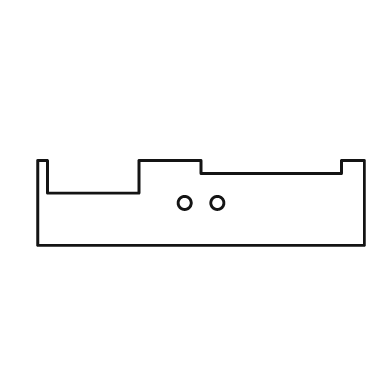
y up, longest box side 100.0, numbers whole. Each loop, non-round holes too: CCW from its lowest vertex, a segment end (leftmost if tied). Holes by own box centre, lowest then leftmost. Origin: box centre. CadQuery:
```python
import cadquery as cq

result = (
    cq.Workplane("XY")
    .moveTo(-50.0, -13.0)
    .lineTo(50.0, -13.0)
    .lineTo(50.0, 13.0)
    .lineTo(43.0, 13.0)
    .lineTo(43.0, 9.0)
    .lineTo(0.0, 9.0)
    .lineTo(0.0, 13.0)
    .lineTo(-19.0, 13.0)
    .lineTo(-19.0, 3.0)
    .lineTo(-47.0, 3.0)
    .lineTo(-47.0, 13.0)
    .lineTo(-50.0, 13.0)
    .close()
    .moveTo(-5.0, 0.0)
    .circle(2.0)
    .moveTo(5.0, 0.0)
    .circle(2.0)
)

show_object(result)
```